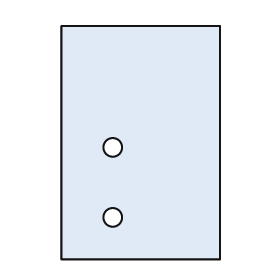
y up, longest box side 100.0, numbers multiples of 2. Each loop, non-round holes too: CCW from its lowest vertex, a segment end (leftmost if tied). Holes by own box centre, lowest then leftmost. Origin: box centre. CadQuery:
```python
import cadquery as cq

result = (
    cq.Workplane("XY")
    .moveTo(-34.0, -50.0)
    .lineTo(34.0, -50.0)
    .lineTo(34.0, 50.0)
    .lineTo(-34.0, 50.0)
    .close()
    .moveTo(-12.0, -32.0)
    .circle(4.0)
    .moveTo(-12.0, -2.0)
    .circle(4.0)
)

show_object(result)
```